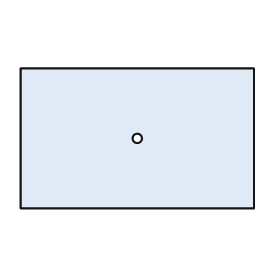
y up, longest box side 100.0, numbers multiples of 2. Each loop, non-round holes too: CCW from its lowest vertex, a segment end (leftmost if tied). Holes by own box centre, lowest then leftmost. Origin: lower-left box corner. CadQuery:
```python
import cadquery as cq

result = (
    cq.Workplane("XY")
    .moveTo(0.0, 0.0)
    .lineTo(100.0, 0.0)
    .lineTo(100.0, 60.0)
    .lineTo(0.0, 60.0)
    .close()
    .moveTo(50.0, 30.0)
    .circle(2.0)
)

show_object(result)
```